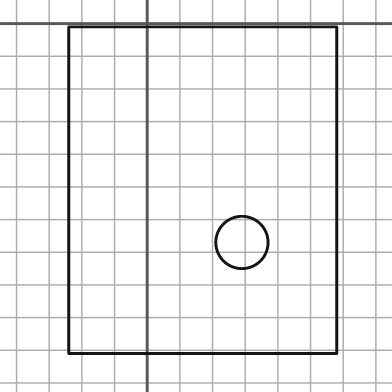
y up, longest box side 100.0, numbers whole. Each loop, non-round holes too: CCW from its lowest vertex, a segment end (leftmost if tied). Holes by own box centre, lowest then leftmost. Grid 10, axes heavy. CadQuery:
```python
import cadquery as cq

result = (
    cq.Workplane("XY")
    .moveTo(-24.0, -101.0)
    .lineTo(58.0, -101.0)
    .lineTo(58.0, -1.0)
    .lineTo(-24.0, -1.0)
    .close()
    .moveTo(29.0, -67.0)
    .circle(8.0)
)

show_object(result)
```